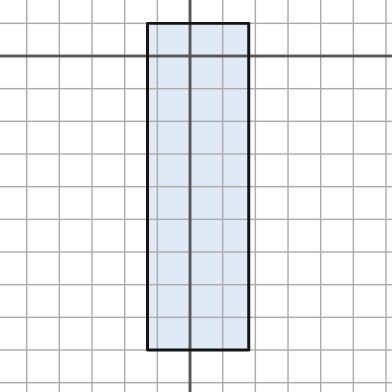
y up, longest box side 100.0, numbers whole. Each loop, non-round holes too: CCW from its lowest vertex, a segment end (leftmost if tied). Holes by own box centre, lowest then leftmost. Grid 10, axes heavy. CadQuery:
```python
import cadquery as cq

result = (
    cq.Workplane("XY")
    .moveTo(-13.0, -90.0)
    .lineTo(18.0, -90.0)
    .lineTo(18.0, 10.0)
    .lineTo(-13.0, 10.0)
    .close()
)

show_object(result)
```